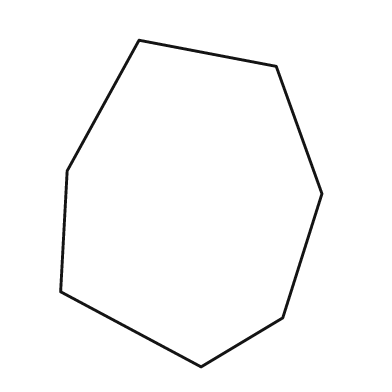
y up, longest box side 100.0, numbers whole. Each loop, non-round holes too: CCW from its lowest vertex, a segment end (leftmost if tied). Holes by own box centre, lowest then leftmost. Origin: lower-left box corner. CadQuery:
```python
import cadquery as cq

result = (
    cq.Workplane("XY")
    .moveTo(43.0, 0.0)
    .lineTo(68.0, 15.0)
    .lineTo(80.0, 53.0)
    .lineTo(66.0, 92.0)
    .lineTo(24.0, 100.0)
    .lineTo(2.0, 60.0)
    .lineTo(0.0, 23.0)
    .close()
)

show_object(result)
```